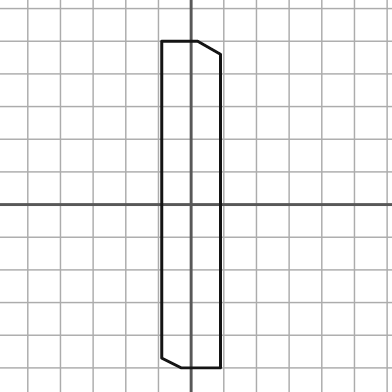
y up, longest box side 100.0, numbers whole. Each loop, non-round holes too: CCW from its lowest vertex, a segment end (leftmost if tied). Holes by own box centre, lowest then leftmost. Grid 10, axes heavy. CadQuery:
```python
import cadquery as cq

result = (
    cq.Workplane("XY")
    .moveTo(-3.0, -50.0)
    .lineTo(9.0, -50.0)
    .lineTo(9.0, 46.0)
    .lineTo(2.0, 50.0)
    .lineTo(-9.0, 50.0)
    .lineTo(-9.0, -47.0)
    .close()
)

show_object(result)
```